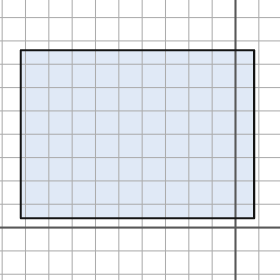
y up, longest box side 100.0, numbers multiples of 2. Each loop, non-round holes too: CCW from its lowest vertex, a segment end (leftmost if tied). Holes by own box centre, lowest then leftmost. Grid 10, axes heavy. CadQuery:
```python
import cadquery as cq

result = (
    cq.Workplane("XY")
    .moveTo(-92.0, 4.0)
    .lineTo(8.0, 4.0)
    .lineTo(8.0, 76.0)
    .lineTo(-92.0, 76.0)
    .close()
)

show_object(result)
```